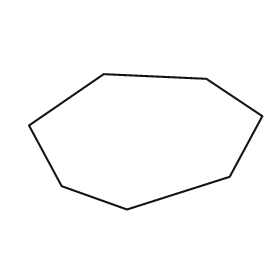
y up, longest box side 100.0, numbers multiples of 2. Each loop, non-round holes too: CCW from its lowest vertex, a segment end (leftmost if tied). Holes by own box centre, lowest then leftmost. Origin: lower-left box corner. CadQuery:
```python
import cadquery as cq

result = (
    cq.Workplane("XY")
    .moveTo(42.0, 0.0)
    .lineTo(86.0, 14.0)
    .lineTo(100.0, 40.0)
    .lineTo(76.0, 56.0)
    .lineTo(32.0, 58.0)
    .lineTo(0.0, 36.0)
    .lineTo(14.0, 10.0)
    .close()
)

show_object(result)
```